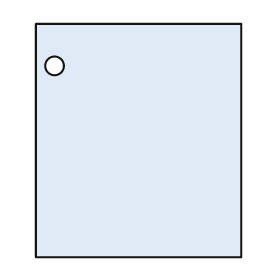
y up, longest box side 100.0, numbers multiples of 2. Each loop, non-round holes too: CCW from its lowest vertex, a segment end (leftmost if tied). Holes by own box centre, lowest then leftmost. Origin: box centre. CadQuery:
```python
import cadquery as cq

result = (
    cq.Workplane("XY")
    .moveTo(-44.0, -50.0)
    .lineTo(44.0, -50.0)
    .lineTo(44.0, 50.0)
    .lineTo(-44.0, 50.0)
    .close()
    .moveTo(-36.0, 32.0)
    .circle(4.0)
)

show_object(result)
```